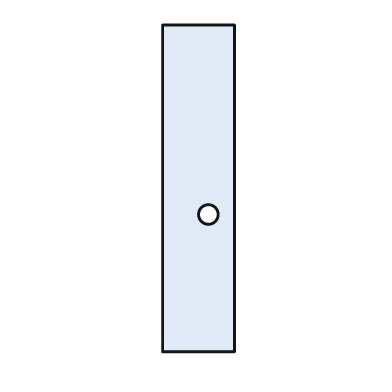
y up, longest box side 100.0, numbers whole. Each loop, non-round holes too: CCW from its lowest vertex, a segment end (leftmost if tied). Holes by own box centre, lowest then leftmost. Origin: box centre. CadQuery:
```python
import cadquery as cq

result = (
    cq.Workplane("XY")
    .moveTo(-11.0, -50.0)
    .lineTo(11.0, -50.0)
    .lineTo(11.0, 50.0)
    .lineTo(-11.0, 50.0)
    .close()
    .moveTo(3.0, -8.0)
    .circle(3.0)
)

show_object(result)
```